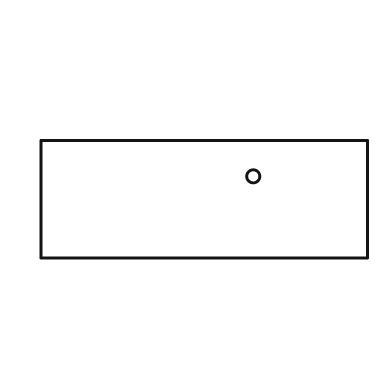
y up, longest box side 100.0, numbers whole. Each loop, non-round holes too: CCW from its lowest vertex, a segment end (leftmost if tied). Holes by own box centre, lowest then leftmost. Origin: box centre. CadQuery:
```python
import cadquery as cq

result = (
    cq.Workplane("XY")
    .moveTo(-50.0, -18.0)
    .lineTo(50.0, -18.0)
    .lineTo(50.0, 18.0)
    .lineTo(-50.0, 18.0)
    .close()
    .moveTo(15.0, 7.0)
    .circle(2.0)
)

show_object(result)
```